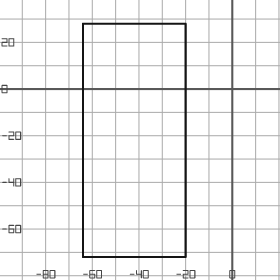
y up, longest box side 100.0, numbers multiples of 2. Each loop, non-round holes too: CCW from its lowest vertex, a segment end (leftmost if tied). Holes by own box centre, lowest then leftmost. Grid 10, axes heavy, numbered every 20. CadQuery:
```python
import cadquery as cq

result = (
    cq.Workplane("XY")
    .moveTo(-64.0, -72.0)
    .lineTo(-20.0, -72.0)
    .lineTo(-20.0, 28.0)
    .lineTo(-64.0, 28.0)
    .close()
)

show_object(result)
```